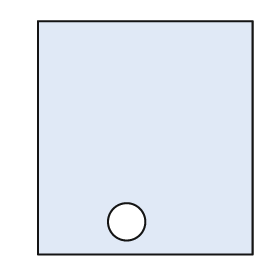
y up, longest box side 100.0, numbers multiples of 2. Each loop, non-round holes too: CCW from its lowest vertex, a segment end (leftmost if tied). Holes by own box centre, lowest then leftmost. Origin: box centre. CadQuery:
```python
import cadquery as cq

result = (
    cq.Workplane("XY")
    .moveTo(-46.0, -50.0)
    .lineTo(46.0, -50.0)
    .lineTo(46.0, 50.0)
    .lineTo(-46.0, 50.0)
    .close()
    .moveTo(-8.0, -36.0)
    .circle(8.0)
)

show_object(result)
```